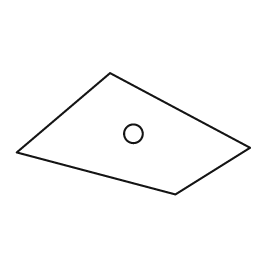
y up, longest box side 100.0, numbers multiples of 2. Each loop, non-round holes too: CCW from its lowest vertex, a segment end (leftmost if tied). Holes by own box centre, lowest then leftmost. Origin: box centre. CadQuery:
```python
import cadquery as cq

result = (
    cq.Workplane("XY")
    .moveTo(18.0, -26.0)
    .lineTo(50.0, -6.0)
    .lineTo(-10.0, 26.0)
    .lineTo(-50.0, -8.0)
    .close()
    .moveTo(0.0, 0.0)
    .circle(4.0)
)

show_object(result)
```